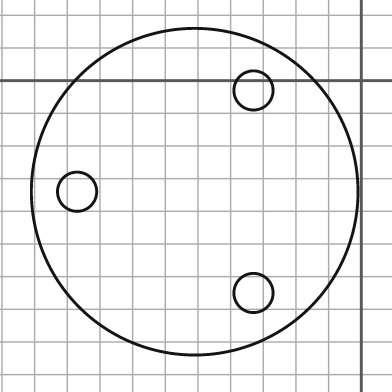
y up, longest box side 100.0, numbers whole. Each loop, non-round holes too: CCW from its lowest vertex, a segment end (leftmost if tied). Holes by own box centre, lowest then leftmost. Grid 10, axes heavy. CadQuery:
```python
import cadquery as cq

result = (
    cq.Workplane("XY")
    .moveTo(-51.0, -34.0)
    .circle(50.0)
    .moveTo(-33.0, -65.0)
    .circle(6.0)
    .moveTo(-87.0, -34.0)
    .circle(6.0)
    .moveTo(-33.0, -3.0)
    .circle(6.0)
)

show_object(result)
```